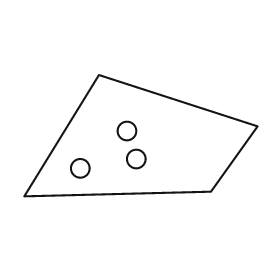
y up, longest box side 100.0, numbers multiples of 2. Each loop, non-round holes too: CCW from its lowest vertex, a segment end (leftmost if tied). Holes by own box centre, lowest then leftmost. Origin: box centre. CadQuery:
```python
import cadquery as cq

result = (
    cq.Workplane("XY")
    .moveTo(-50.0, -26.0)
    .lineTo(30.0, -24.0)
    .lineTo(50.0, 4.0)
    .lineTo(-18.0, 26.0)
    .close()
    .moveTo(-26.0, -14.0)
    .circle(4.0)
    .moveTo(-2.0, -10.0)
    .circle(4.0)
    .moveTo(-6.0, 2.0)
    .circle(4.0)
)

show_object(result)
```